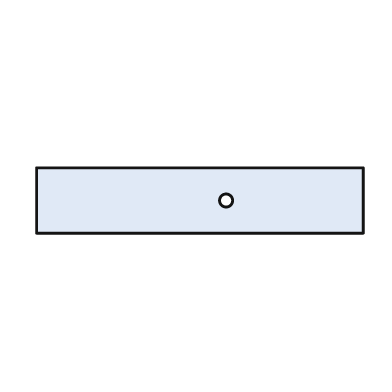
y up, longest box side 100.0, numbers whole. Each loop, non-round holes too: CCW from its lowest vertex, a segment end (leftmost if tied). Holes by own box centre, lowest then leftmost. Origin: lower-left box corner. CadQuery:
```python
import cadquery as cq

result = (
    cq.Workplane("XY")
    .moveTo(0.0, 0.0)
    .lineTo(100.0, 0.0)
    .lineTo(100.0, 20.0)
    .lineTo(0.0, 20.0)
    .close()
    .moveTo(58.0, 10.0)
    .circle(2.0)
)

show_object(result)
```